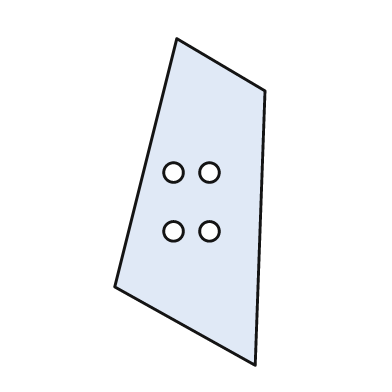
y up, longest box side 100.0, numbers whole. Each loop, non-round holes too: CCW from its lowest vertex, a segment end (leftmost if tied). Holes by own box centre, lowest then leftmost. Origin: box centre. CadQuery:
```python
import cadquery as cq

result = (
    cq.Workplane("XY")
    .moveTo(20.0, -50.0)
    .lineTo(23.0, 34.0)
    .lineTo(-4.0, 50.0)
    .lineTo(-23.0, -26.0)
    .close()
    .moveTo(-5.0, -9.0)
    .circle(3.0)
    .moveTo(6.0, -9.0)
    .circle(3.0)
    .moveTo(-5.0, 9.0)
    .circle(3.0)
    .moveTo(6.0, 9.0)
    .circle(3.0)
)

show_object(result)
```